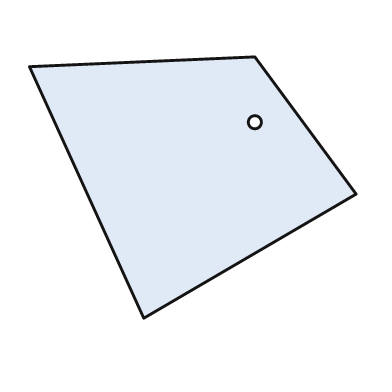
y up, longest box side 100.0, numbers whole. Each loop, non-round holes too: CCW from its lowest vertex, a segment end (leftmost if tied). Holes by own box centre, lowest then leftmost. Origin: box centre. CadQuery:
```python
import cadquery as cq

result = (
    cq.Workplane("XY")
    .moveTo(-15.0, -40.0)
    .lineTo(50.0, -2.0)
    .lineTo(19.0, 40.0)
    .lineTo(-50.0, 37.0)
    .close()
    .moveTo(19.0, 20.0)
    .circle(2.0)
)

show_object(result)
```